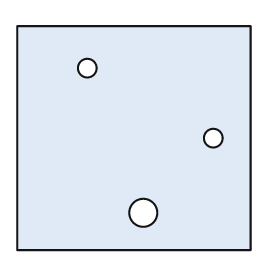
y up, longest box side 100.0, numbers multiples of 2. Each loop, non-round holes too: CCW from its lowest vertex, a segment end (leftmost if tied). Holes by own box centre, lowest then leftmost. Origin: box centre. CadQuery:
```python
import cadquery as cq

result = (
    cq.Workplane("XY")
    .moveTo(-50.0, -48.0)
    .lineTo(50.0, -48.0)
    .lineTo(50.0, 48.0)
    .lineTo(-50.0, 48.0)
    .close()
    .moveTo(4.0, -32.0)
    .circle(6.0)
    .moveTo(34.0, 0.0)
    .circle(4.0)
    .moveTo(-20.0, 30.0)
    .circle(4.0)
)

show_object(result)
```